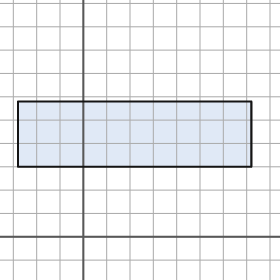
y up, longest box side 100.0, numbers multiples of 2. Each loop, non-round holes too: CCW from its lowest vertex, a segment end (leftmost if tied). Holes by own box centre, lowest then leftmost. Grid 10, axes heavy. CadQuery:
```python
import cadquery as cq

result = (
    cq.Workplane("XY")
    .moveTo(-28.0, 30.0)
    .lineTo(72.0, 30.0)
    .lineTo(72.0, 58.0)
    .lineTo(-28.0, 58.0)
    .close()
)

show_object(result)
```